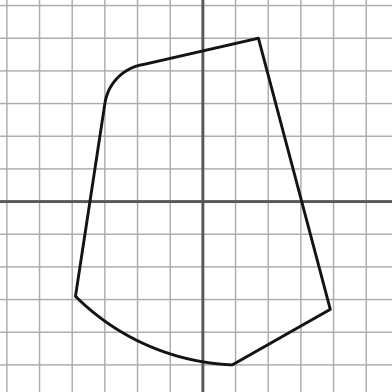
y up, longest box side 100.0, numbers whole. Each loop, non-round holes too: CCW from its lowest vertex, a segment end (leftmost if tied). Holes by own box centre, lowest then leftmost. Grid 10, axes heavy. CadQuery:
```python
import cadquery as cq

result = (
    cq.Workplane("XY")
    .moveTo(9.0, -50.0)
    .lineTo(39.0, -33.0)
    .lineTo(17.0, 50.0)
    .lineTo(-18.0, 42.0)
    .threePointArc((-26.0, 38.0), (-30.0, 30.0))
    .lineTo(-39.0, -29.0)
    .threePointArc((-17.0, -44.0), (9.0, -50.0))
    .close()
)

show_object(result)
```